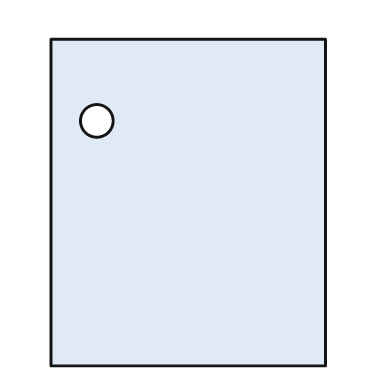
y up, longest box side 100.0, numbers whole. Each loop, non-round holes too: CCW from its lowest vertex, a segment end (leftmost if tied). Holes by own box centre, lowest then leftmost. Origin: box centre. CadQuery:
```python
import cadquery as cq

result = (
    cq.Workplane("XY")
    .moveTo(-42.0, -50.0)
    .lineTo(42.0, -50.0)
    .lineTo(42.0, 50.0)
    .lineTo(-42.0, 50.0)
    .close()
    .moveTo(-28.0, 25.0)
    .circle(5.0)
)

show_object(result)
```